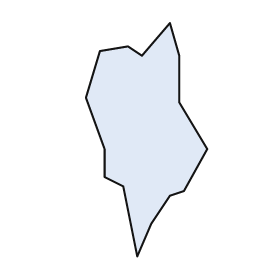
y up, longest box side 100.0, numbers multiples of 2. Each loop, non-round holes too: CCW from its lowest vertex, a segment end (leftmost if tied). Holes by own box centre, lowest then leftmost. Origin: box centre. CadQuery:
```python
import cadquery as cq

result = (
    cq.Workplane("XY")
    .moveTo(-4.0, -50.0)
    .lineTo(2.0, -36.0)
    .lineTo(10.0, -24.0)
    .lineTo(16.0, -22.0)
    .lineTo(26.0, -4.0)
    .lineTo(14.0, 16.0)
    .lineTo(14.0, 36.0)
    .lineTo(10.0, 50.0)
    .lineTo(-2.0, 36.0)
    .lineTo(-8.0, 40.0)
    .lineTo(-20.0, 38.0)
    .lineTo(-26.0, 18.0)
    .lineTo(-18.0, -4.0)
    .lineTo(-18.0, -16.0)
    .lineTo(-10.0, -20.0)
    .close()
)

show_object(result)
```